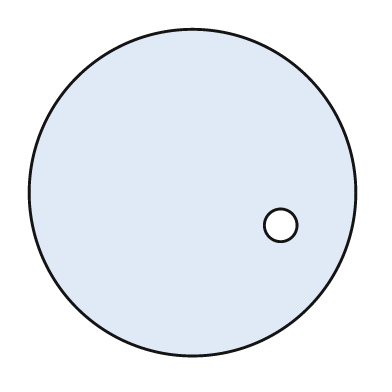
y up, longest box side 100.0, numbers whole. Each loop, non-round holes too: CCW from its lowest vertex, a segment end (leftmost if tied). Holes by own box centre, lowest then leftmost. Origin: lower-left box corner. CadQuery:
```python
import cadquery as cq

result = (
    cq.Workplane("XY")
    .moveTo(50.0, 50.0)
    .circle(50.0)
    .moveTo(77.0, 40.0)
    .circle(5.0)
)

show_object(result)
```